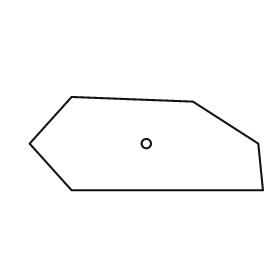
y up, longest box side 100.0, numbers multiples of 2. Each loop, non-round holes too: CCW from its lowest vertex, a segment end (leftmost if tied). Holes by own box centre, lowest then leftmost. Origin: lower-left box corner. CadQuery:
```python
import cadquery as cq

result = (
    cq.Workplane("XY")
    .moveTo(18.0, 0.0)
    .lineTo(100.0, 0.0)
    .lineTo(98.0, 20.0)
    .lineTo(70.0, 38.0)
    .lineTo(18.0, 40.0)
    .lineTo(0.0, 20.0)
    .close()
    .moveTo(50.0, 20.0)
    .circle(2.0)
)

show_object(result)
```